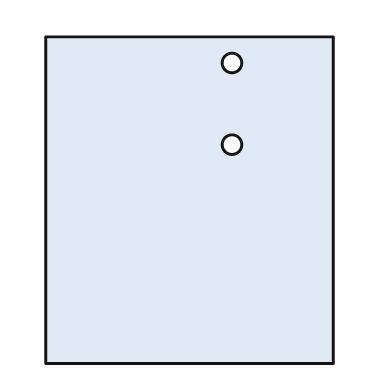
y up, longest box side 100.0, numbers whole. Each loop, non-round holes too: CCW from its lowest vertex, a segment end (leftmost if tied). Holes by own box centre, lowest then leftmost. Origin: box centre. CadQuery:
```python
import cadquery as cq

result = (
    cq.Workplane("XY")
    .moveTo(-44.0, -50.0)
    .lineTo(44.0, -50.0)
    .lineTo(44.0, 50.0)
    .lineTo(-44.0, 50.0)
    .close()
    .moveTo(13.0, 17.0)
    .circle(3.0)
    .moveTo(13.0, 42.0)
    .circle(3.0)
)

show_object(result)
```